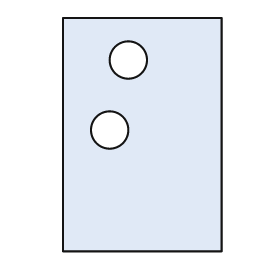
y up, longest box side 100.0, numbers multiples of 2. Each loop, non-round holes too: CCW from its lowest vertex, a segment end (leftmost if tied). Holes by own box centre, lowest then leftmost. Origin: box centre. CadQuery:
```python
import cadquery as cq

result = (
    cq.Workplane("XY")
    .moveTo(-34.0, -50.0)
    .lineTo(34.0, -50.0)
    .lineTo(34.0, 50.0)
    .lineTo(-34.0, 50.0)
    .close()
    .moveTo(-14.0, 2.0)
    .circle(8.0)
    .moveTo(-6.0, 32.0)
    .circle(8.0)
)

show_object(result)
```